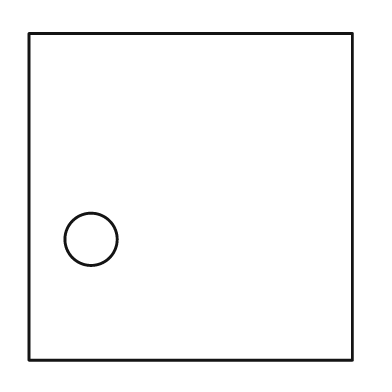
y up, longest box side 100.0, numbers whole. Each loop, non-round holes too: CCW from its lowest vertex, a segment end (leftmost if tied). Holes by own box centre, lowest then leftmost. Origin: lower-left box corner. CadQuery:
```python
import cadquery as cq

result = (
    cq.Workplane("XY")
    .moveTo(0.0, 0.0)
    .lineTo(99.0, 0.0)
    .lineTo(99.0, 100.0)
    .lineTo(0.0, 100.0)
    .close()
    .moveTo(19.0, 37.0)
    .circle(8.0)
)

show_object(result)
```